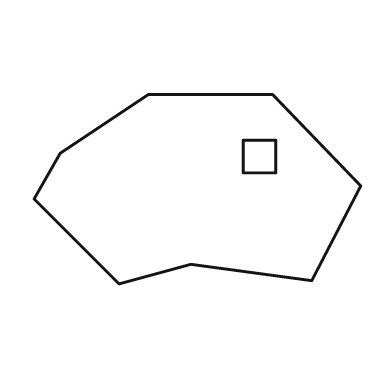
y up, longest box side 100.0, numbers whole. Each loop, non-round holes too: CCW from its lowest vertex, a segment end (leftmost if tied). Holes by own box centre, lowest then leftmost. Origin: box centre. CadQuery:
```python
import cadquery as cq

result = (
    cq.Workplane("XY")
    .moveTo(-24.0, -29.0)
    .lineTo(-2.0, -23.0)
    .lineTo(35.0, -28.0)
    .lineTo(50.0, 1.0)
    .lineTo(23.0, 29.0)
    .lineTo(-15.0, 29.0)
    .lineTo(-42.0, 11.0)
    .lineTo(-50.0, -3.0)
    .close()
    .moveTo(14.0, 5.0)
    .lineTo(24.0, 5.0)
    .lineTo(24.0, 15.0)
    .lineTo(14.0, 15.0)
    .close()
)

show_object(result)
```